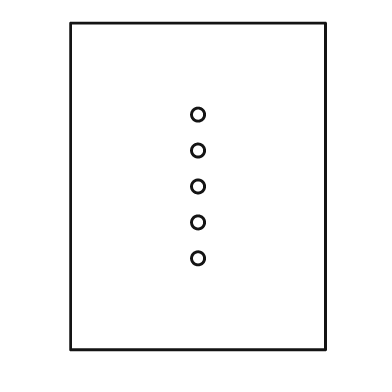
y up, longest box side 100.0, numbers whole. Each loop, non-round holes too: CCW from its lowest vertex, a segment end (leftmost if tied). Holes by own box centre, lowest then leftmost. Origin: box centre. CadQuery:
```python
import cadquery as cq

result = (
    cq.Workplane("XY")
    .moveTo(-39.0, -50.0)
    .lineTo(39.0, -50.0)
    .lineTo(39.0, 50.0)
    .lineTo(-39.0, 50.0)
    .close()
    .moveTo(0.0, -22.0)
    .circle(2.0)
    .moveTo(0.0, -11.0)
    .circle(2.0)
    .moveTo(0.0, 0.0)
    .circle(2.0)
    .moveTo(0.0, 11.0)
    .circle(2.0)
    .moveTo(0.0, 22.0)
    .circle(2.0)
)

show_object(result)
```